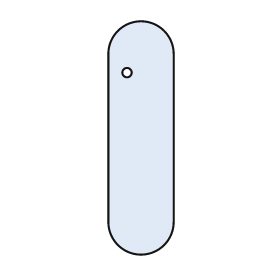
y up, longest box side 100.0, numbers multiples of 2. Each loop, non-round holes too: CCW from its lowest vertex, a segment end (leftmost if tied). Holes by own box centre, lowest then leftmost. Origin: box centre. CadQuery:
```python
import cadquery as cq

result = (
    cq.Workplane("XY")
    .moveTo(-14.0, -36.0)
    .threePointArc((0.0, -50.0), (14.0, -36.0))
    .lineTo(14.0, 36.0)
    .threePointArc((0.0, 50.0), (-14.0, 36.0))
    .close()
    .moveTo(-6.0, 28.0)
    .circle(2.0)
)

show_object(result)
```